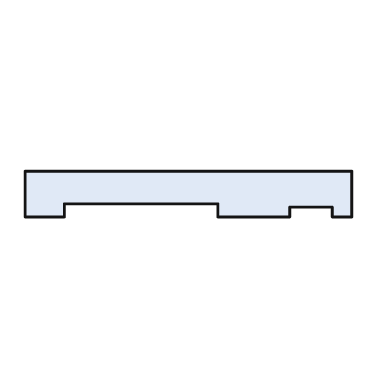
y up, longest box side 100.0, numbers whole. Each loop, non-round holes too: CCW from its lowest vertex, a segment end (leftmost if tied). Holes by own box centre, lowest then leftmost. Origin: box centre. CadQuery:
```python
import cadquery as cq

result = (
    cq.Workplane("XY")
    .moveTo(-50.0, -7.0)
    .lineTo(-38.0, -7.0)
    .lineTo(-38.0, -3.0)
    .lineTo(9.0, -3.0)
    .lineTo(9.0, -7.0)
    .lineTo(31.0, -7.0)
    .lineTo(31.0, -4.0)
    .lineTo(44.0, -4.0)
    .lineTo(44.0, -7.0)
    .lineTo(50.0, -7.0)
    .lineTo(50.0, 7.0)
    .lineTo(-50.0, 7.0)
    .close()
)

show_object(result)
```